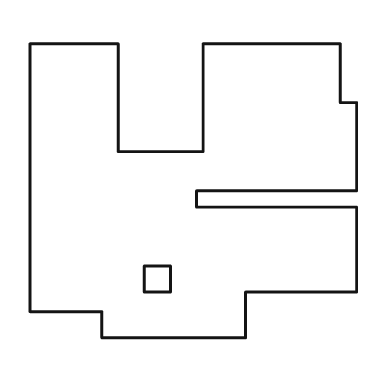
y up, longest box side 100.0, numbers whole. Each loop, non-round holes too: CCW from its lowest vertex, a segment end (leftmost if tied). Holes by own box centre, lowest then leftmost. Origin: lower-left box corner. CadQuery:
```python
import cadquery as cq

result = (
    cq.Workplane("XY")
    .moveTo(22.0, 0.0)
    .lineTo(66.0, 0.0)
    .lineTo(66.0, 14.0)
    .lineTo(100.0, 14.0)
    .lineTo(100.0, 40.0)
    .lineTo(51.0, 40.0)
    .lineTo(51.0, 45.0)
    .lineTo(100.0, 45.0)
    .lineTo(100.0, 72.0)
    .lineTo(95.0, 72.0)
    .lineTo(95.0, 90.0)
    .lineTo(53.0, 90.0)
    .lineTo(53.0, 57.0)
    .lineTo(27.0, 57.0)
    .lineTo(27.0, 90.0)
    .lineTo(0.0, 90.0)
    .lineTo(0.0, 8.0)
    .lineTo(22.0, 8.0)
    .close()
    .moveTo(35.0, 14.0)
    .lineTo(43.0, 14.0)
    .lineTo(43.0, 22.0)
    .lineTo(35.0, 22.0)
    .close()
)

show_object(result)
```